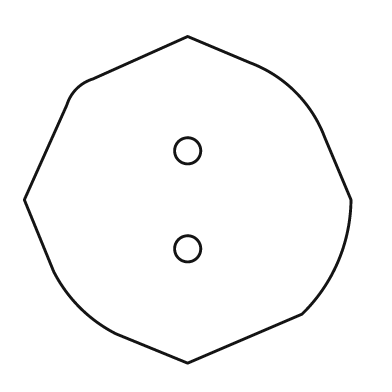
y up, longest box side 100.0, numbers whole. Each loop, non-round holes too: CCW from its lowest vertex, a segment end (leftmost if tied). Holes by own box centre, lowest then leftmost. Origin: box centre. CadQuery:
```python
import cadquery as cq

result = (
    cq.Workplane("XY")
    .moveTo(0.0, -50.0)
    .lineTo(35.0, -35.0)
    .threePointArc((46.0, -19.0), (50.0, 0.0))
    .lineTo(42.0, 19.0)
    .threePointArc((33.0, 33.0), (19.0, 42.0))
    .lineTo(0.0, 50.0)
    .lineTo(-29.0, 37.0)
    .threePointArc((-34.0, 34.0), (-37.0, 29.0))
    .lineTo(-50.0, 0.0)
    .lineTo(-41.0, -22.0)
    .threePointArc((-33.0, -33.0), (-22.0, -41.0))
    .close()
    .moveTo(0.0, -15.0)
    .circle(4.0)
    .moveTo(0.0, 15.0)
    .circle(4.0)
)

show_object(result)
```